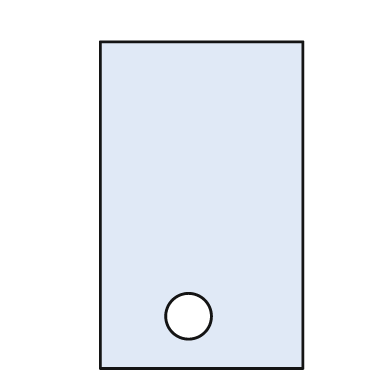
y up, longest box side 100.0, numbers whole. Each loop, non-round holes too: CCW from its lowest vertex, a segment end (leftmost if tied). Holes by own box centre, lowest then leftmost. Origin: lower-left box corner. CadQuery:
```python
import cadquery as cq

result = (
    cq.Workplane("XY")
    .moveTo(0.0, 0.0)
    .lineTo(62.0, 0.0)
    .lineTo(62.0, 100.0)
    .lineTo(0.0, 100.0)
    .close()
    .moveTo(27.0, 16.0)
    .circle(7.0)
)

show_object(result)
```